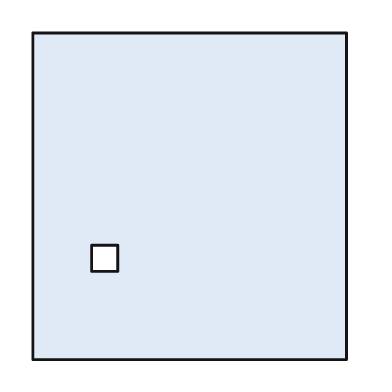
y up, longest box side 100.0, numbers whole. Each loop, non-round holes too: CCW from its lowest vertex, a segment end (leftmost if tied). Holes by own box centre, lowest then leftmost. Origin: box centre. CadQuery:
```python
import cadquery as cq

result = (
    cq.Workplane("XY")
    .moveTo(-48.0, -50.0)
    .lineTo(48.0, -50.0)
    .lineTo(48.0, 50.0)
    .lineTo(-48.0, 50.0)
    .close()
    .moveTo(-30.0, -23.0)
    .lineTo(-22.0, -23.0)
    .lineTo(-22.0, -15.0)
    .lineTo(-30.0, -15.0)
    .close()
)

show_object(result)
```